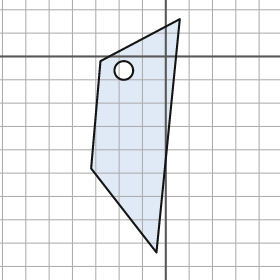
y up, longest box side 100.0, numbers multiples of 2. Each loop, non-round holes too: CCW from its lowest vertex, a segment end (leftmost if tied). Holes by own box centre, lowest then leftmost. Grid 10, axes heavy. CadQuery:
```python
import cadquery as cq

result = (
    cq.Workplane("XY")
    .moveTo(-4.0, -84.0)
    .lineTo(6.0, 16.0)
    .lineTo(-28.0, -2.0)
    .lineTo(-32.0, -48.0)
    .close()
    .moveTo(-18.0, -6.0)
    .circle(4.0)
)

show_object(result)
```